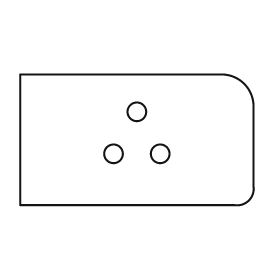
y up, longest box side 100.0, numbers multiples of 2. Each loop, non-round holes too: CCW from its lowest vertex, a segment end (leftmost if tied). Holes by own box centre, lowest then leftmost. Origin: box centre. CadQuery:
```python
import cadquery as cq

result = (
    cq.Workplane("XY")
    .moveTo(-50.0, -28.0)
    .lineTo(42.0, -28.0)
    .threePointArc((48.0, -26.0), (50.0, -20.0))
    .lineTo(50.0, 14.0)
    .threePointArc((46.0, 24.0), (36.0, 28.0))
    .lineTo(-50.0, 28.0)
    .close()
    .moveTo(-10.0, -6.0)
    .circle(4.0)
    .moveTo(10.0, -6.0)
    .circle(4.0)
    .moveTo(0.0, 12.0)
    .circle(4.0)
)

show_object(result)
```